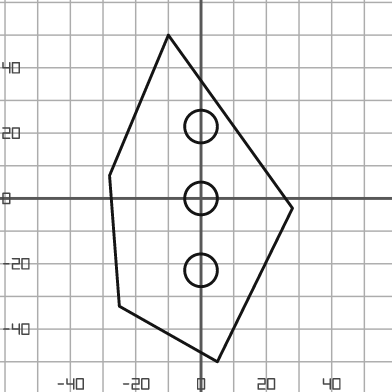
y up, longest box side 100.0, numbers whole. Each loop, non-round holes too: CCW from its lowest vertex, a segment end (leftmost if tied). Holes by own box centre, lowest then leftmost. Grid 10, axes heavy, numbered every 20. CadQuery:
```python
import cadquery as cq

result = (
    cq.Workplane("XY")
    .moveTo(5.0, -50.0)
    .lineTo(28.0, -3.0)
    .lineTo(-10.0, 50.0)
    .lineTo(-28.0, 7.0)
    .lineTo(-25.0, -33.0)
    .close()
    .moveTo(0.0, -22.0)
    .circle(5.0)
    .moveTo(0.0, 0.0)
    .circle(5.0)
    .moveTo(0.0, 22.0)
    .circle(5.0)
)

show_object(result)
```